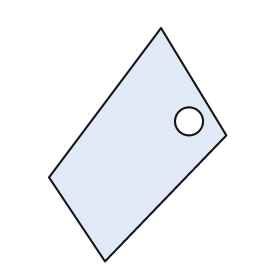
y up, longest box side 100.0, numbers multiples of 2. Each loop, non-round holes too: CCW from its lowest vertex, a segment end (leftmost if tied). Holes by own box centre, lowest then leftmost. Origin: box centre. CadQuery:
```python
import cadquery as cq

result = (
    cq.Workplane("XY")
    .moveTo(-14.0, -50.0)
    .lineTo(38.0, 4.0)
    .lineTo(10.0, 50.0)
    .lineTo(-38.0, -14.0)
    .close()
    .moveTo(22.0, 10.0)
    .circle(6.0)
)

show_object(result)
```